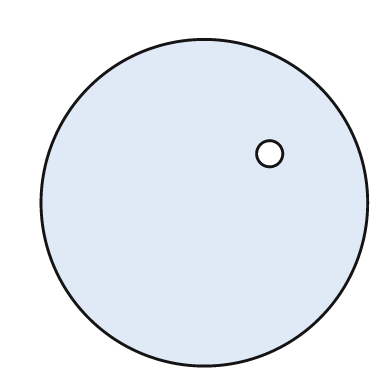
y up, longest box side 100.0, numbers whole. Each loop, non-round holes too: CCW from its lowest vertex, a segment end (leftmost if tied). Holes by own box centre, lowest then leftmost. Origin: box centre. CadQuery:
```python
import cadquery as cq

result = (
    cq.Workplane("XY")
    .moveTo(0.0, 0.0)
    .circle(50.0)
    .moveTo(20.0, 15.0)
    .circle(4.0)
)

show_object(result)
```